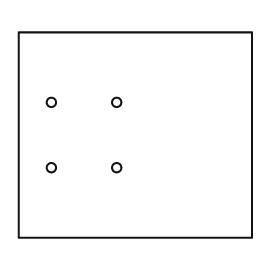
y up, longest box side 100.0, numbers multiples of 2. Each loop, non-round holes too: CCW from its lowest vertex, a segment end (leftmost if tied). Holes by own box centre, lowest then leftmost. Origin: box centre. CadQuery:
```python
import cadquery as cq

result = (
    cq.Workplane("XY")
    .moveTo(-50.0, -44.0)
    .lineTo(50.0, -44.0)
    .lineTo(50.0, 44.0)
    .lineTo(-50.0, 44.0)
    .close()
    .moveTo(-36.0, -14.0)
    .circle(2.0)
    .moveTo(-8.0, -14.0)
    .circle(2.0)
    .moveTo(-36.0, 14.0)
    .circle(2.0)
    .moveTo(-8.0, 14.0)
    .circle(2.0)
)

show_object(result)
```